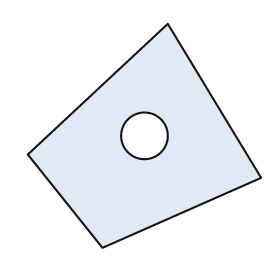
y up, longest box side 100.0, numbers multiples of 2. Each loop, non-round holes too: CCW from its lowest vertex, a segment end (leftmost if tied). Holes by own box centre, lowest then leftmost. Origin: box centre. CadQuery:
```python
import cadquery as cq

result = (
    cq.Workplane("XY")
    .moveTo(-18.0, -48.0)
    .lineTo(50.0, -18.0)
    .lineTo(10.0, 48.0)
    .lineTo(-50.0, -8.0)
    .close()
    .moveTo(0.0, 0.0)
    .circle(10.0)
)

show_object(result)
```